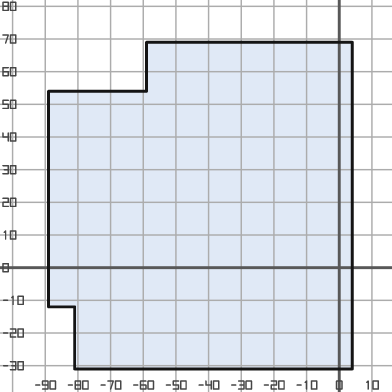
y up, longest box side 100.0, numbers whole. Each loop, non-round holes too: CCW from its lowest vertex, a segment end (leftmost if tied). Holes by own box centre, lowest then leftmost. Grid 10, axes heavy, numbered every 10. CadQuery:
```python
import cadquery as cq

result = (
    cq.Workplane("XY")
    .moveTo(-81.0, -31.0)
    .lineTo(4.0, -31.0)
    .lineTo(4.0, 69.0)
    .lineTo(-59.0, 69.0)
    .lineTo(-59.0, 54.0)
    .lineTo(-89.0, 54.0)
    .lineTo(-89.0, -12.0)
    .lineTo(-81.0, -12.0)
    .close()
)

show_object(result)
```